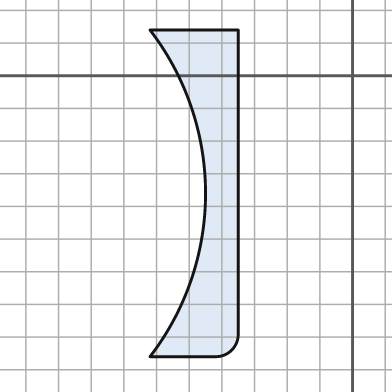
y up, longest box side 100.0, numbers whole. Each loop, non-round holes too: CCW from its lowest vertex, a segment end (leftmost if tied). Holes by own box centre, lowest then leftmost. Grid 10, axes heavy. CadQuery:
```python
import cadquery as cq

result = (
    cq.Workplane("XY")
    .moveTo(-62.0, -86.0)
    .lineTo(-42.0, -86.0)
    .threePointArc((-37.0, -84.0), (-35.0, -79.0))
    .lineTo(-35.0, 14.0)
    .lineTo(-62.0, 14.0)
    .threePointArc((-45.0, -36.0), (-62.0, -86.0))
    .close()
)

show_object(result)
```